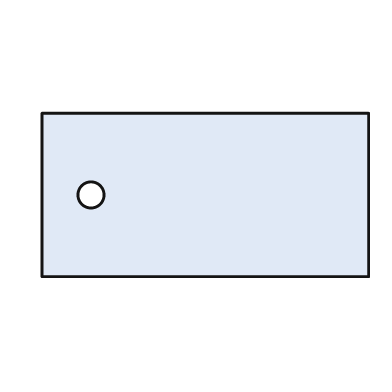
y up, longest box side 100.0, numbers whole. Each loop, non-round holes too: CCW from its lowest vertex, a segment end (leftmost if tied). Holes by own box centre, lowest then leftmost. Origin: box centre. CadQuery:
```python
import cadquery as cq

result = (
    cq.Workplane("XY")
    .moveTo(-50.0, -25.0)
    .lineTo(50.0, -25.0)
    .lineTo(50.0, 25.0)
    .lineTo(-50.0, 25.0)
    .close()
    .moveTo(-35.0, 0.0)
    .circle(4.0)
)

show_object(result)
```